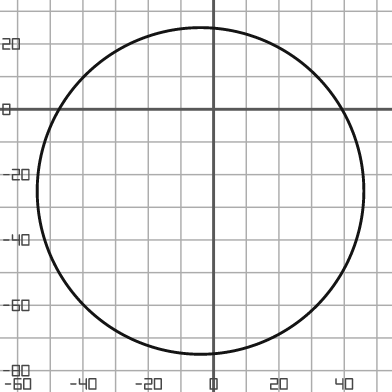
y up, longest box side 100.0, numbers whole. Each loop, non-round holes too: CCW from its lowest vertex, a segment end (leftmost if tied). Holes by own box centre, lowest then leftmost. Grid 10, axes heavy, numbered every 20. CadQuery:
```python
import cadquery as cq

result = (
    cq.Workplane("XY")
    .moveTo(-4.0, -25.0)
    .circle(50.0)
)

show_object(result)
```